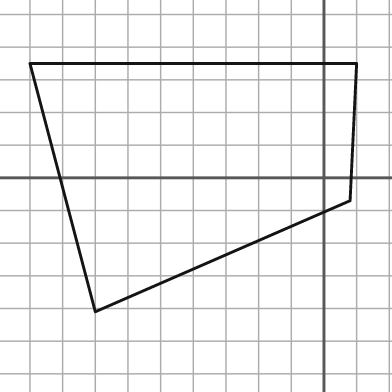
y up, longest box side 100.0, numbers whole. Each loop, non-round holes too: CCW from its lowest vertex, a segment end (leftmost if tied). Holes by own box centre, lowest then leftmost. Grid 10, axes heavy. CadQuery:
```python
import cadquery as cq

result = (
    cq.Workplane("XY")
    .moveTo(-70.0, -41.0)
    .lineTo(8.0, -7.0)
    .lineTo(10.0, 35.0)
    .lineTo(-90.0, 35.0)
    .close()
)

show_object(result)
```